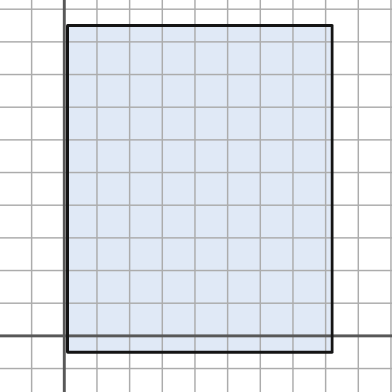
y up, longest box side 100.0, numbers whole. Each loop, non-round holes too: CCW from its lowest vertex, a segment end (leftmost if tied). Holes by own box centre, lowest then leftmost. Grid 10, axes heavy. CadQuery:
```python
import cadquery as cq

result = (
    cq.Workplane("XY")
    .moveTo(1.0, -5.0)
    .lineTo(82.0, -5.0)
    .lineTo(82.0, 95.0)
    .lineTo(1.0, 95.0)
    .close()
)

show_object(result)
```